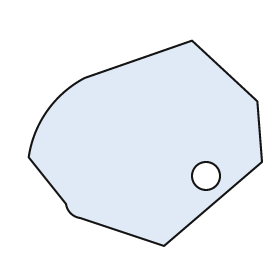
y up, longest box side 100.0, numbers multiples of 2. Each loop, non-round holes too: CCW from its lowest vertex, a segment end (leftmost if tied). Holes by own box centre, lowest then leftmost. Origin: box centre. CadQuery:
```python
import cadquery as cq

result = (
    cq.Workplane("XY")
    .moveTo(8.0, -44.0)
    .lineTo(50.0, -8.0)
    .lineTo(48.0, 18.0)
    .lineTo(20.0, 44.0)
    .lineTo(-26.0, 28.0)
    .threePointArc((-42.0, 14.0), (-50.0, -6.0))
    .lineTo(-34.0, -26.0)
    .threePointArc((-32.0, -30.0), (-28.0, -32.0))
    .close()
    .moveTo(26.0, -14.0)
    .circle(6.0)
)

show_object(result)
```